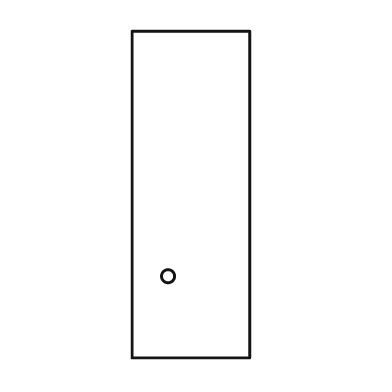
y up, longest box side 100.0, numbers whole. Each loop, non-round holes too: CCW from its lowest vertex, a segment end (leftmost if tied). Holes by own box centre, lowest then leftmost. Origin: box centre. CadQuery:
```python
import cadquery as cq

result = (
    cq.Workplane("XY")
    .moveTo(-18.0, -50.0)
    .lineTo(18.0, -50.0)
    .lineTo(18.0, 50.0)
    .lineTo(-18.0, 50.0)
    .close()
    .moveTo(-7.0, -25.0)
    .circle(2.0)
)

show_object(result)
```